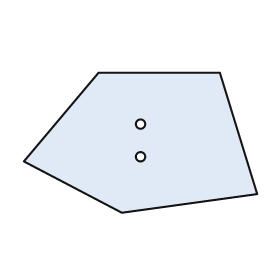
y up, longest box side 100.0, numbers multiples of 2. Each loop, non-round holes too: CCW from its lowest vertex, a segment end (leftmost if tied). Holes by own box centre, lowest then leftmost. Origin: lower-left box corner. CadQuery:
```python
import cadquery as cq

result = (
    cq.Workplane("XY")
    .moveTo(42.0, 0.0)
    .lineTo(100.0, 8.0)
    .lineTo(84.0, 60.0)
    .lineTo(32.0, 60.0)
    .lineTo(0.0, 22.0)
    .close()
    .moveTo(50.0, 24.0)
    .circle(2.0)
    .moveTo(50.0, 38.0)
    .circle(2.0)
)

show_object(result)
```